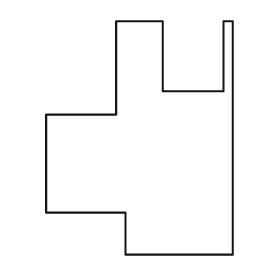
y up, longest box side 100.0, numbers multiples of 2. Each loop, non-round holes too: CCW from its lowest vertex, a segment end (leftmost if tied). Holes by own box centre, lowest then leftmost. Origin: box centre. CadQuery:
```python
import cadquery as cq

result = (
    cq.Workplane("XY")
    .moveTo(-6.0, -50.0)
    .lineTo(40.0, -50.0)
    .lineTo(40.0, 50.0)
    .lineTo(36.0, 50.0)
    .lineTo(36.0, 20.0)
    .lineTo(10.0, 20.0)
    .lineTo(10.0, 50.0)
    .lineTo(-10.0, 50.0)
    .lineTo(-10.0, 10.0)
    .lineTo(-40.0, 10.0)
    .lineTo(-40.0, -32.0)
    .lineTo(-6.0, -32.0)
    .close()
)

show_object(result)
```